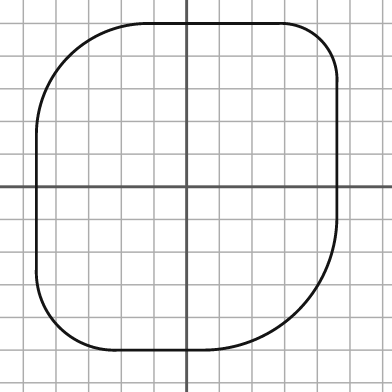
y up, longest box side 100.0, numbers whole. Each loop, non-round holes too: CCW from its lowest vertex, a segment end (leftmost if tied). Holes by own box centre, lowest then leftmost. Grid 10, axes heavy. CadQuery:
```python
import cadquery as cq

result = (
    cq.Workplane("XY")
    .moveTo(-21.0, -50.0)
    .lineTo(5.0, -50.0)
    .threePointArc((34.0, -38.0), (46.0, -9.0))
    .lineTo(46.0, 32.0)
    .threePointArc((41.0, 45.0), (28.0, 50.0))
    .lineTo(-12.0, 50.0)
    .threePointArc((-36.0, 40.0), (-46.0, 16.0))
    .lineTo(-46.0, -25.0)
    .threePointArc((-39.0, -43.0), (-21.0, -50.0))
    .close()
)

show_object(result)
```